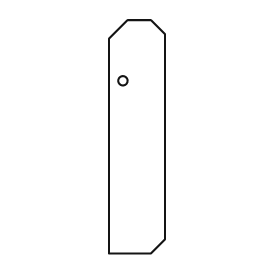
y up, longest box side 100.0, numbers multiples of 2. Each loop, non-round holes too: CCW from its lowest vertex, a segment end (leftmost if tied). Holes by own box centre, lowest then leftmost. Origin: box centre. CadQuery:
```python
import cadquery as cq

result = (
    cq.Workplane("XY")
    .moveTo(-12.0, -50.0)
    .lineTo(6.0, -50.0)
    .lineTo(12.0, -44.0)
    .lineTo(12.0, 44.0)
    .lineTo(6.0, 50.0)
    .lineTo(-4.0, 50.0)
    .lineTo(-12.0, 42.0)
    .close()
    .moveTo(-6.0, 24.0)
    .circle(2.0)
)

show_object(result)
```